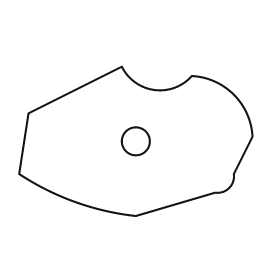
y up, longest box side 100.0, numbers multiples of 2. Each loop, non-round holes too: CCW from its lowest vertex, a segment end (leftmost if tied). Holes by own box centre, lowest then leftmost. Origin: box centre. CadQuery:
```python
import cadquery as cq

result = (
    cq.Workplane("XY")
    .moveTo(0.0, -32.0)
    .lineTo(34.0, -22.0)
    .threePointArc((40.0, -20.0), (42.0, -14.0))
    .lineTo(50.0, 2.0)
    .threePointArc((42.0, 20.0), (24.0, 28.0))
    .threePointArc((8.0, 22.0), (-6.0, 32.0))
    .lineTo(-46.0, 12.0)
    .lineTo(-50.0, -14.0)
    .threePointArc((-26.0, -26.0), (0.0, -32.0))
    .close()
    .moveTo(0.0, 0.0)
    .circle(6.0)
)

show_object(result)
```